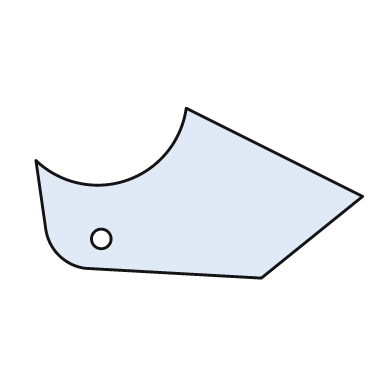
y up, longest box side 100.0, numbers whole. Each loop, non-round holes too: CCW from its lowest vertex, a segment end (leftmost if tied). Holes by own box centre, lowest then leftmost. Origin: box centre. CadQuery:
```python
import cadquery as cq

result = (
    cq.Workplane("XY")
    .moveTo(19.0, -26.0)
    .lineTo(50.0, -1.0)
    .lineTo(-4.0, 26.0)
    .threePointArc((-22.0, 4.0), (-50.0, 10.0))
    .lineTo(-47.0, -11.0)
    .threePointArc((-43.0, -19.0), (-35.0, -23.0))
    .close()
    .moveTo(-30.0, -14.0)
    .circle(3.0)
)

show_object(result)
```